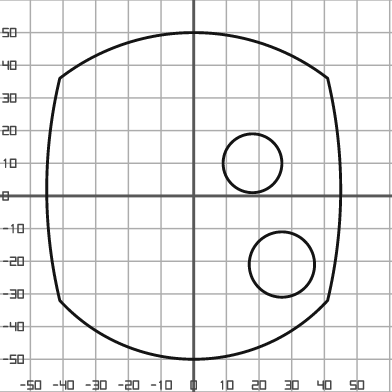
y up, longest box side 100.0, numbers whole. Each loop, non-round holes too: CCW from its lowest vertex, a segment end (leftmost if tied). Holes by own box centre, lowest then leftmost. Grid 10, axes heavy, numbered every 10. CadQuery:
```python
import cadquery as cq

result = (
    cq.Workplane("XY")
    .moveTo(-41.0, -32.0)
    .threePointArc((0.0, -50.0), (41.0, -32.0))
    .threePointArc((45.0, 2.0), (41.0, 36.0))
    .threePointArc((0.0, 50.0), (-41.0, 36.0))
    .threePointArc((-45.0, 2.0), (-41.0, -32.0))
    .close()
    .moveTo(27.0, -21.0)
    .circle(10.0)
    .moveTo(18.0, 10.0)
    .circle(9.0)
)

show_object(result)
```